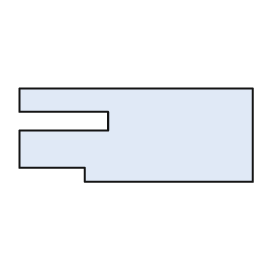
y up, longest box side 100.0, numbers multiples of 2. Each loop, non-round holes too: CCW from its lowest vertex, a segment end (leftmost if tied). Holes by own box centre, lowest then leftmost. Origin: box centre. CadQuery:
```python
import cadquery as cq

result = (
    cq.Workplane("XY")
    .moveTo(-22.0, -20.0)
    .lineTo(50.0, -20.0)
    .lineTo(50.0, 20.0)
    .lineTo(-50.0, 20.0)
    .lineTo(-50.0, 10.0)
    .lineTo(-12.0, 10.0)
    .lineTo(-12.0, 2.0)
    .lineTo(-50.0, 2.0)
    .lineTo(-50.0, -14.0)
    .lineTo(-22.0, -14.0)
    .close()
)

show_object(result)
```